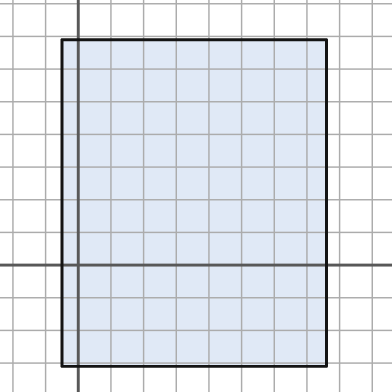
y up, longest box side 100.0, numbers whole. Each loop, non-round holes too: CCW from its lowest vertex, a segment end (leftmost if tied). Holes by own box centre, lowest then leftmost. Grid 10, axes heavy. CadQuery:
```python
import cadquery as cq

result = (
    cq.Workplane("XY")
    .moveTo(-5.0, -31.0)
    .lineTo(76.0, -31.0)
    .lineTo(76.0, 69.0)
    .lineTo(-5.0, 69.0)
    .close()
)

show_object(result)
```